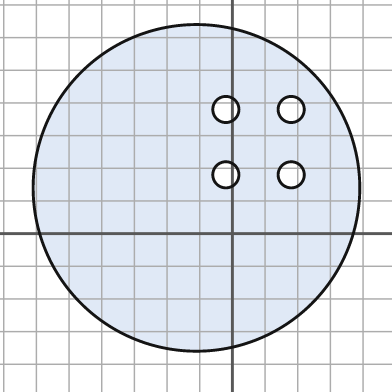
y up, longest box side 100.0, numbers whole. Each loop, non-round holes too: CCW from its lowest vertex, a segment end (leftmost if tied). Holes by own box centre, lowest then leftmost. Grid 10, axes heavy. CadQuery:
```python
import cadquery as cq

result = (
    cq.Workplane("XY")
    .moveTo(-11.0, 14.0)
    .circle(50.0)
    .moveTo(-2.0, 18.0)
    .circle(4.0)
    .moveTo(18.0, 18.0)
    .circle(4.0)
    .moveTo(-2.0, 38.0)
    .circle(4.0)
    .moveTo(18.0, 38.0)
    .circle(4.0)
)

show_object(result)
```